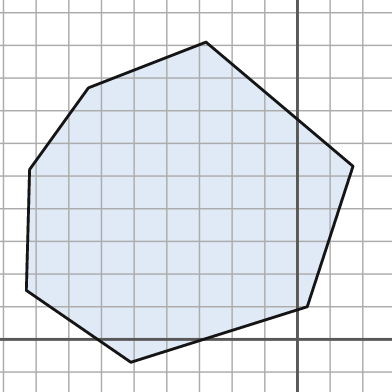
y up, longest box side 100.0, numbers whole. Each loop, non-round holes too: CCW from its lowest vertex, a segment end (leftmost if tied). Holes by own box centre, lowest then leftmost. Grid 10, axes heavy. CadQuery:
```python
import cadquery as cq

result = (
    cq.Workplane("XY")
    .moveTo(-51.0, -7.0)
    .lineTo(3.0, 10.0)
    .lineTo(17.0, 53.0)
    .lineTo(-28.0, 91.0)
    .lineTo(-64.0, 77.0)
    .lineTo(-82.0, 52.0)
    .lineTo(-83.0, 15.0)
    .close()
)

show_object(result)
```